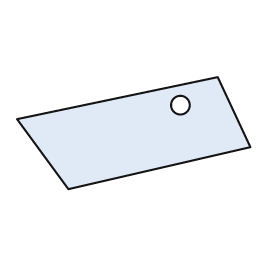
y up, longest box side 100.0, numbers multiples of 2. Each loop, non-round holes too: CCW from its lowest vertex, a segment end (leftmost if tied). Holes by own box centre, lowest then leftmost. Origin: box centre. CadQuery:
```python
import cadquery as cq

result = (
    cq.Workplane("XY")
    .moveTo(-28.0, -24.0)
    .lineTo(50.0, -6.0)
    .lineTo(36.0, 24.0)
    .lineTo(-50.0, 6.0)
    .close()
    .moveTo(20.0, 12.0)
    .circle(4.0)
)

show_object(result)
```